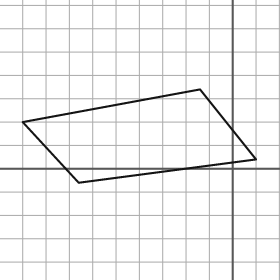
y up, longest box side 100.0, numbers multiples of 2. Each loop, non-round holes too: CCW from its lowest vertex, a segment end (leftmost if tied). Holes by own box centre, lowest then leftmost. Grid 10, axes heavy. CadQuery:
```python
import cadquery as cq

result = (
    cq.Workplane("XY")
    .moveTo(-66.0, -6.0)
    .lineTo(10.0, 4.0)
    .lineTo(-14.0, 34.0)
    .lineTo(-90.0, 20.0)
    .close()
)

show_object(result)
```